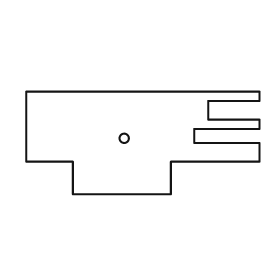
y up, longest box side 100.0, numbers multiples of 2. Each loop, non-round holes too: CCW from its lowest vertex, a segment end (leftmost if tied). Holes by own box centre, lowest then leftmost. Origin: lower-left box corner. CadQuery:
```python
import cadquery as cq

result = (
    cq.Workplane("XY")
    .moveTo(20.0, 0.0)
    .lineTo(62.0, 0.0)
    .lineTo(62.0, 14.0)
    .lineTo(100.0, 14.0)
    .lineTo(100.0, 22.0)
    .lineTo(72.0, 22.0)
    .lineTo(72.0, 28.0)
    .lineTo(100.0, 28.0)
    .lineTo(100.0, 32.0)
    .lineTo(78.0, 32.0)
    .lineTo(78.0, 40.0)
    .lineTo(100.0, 40.0)
    .lineTo(100.0, 44.0)
    .lineTo(0.0, 44.0)
    .lineTo(0.0, 14.0)
    .lineTo(20.0, 14.0)
    .close()
    .moveTo(42.0, 24.0)
    .circle(2.0)
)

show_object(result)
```